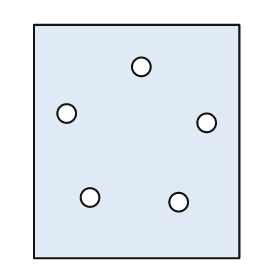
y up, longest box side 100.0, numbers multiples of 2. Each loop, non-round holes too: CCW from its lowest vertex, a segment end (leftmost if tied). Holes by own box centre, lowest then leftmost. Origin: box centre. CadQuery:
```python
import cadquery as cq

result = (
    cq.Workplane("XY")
    .moveTo(-44.0, -50.0)
    .lineTo(44.0, -50.0)
    .lineTo(44.0, 50.0)
    .lineTo(-44.0, 50.0)
    .close()
    .moveTo(18.0, -26.0)
    .circle(4.0)
    .moveTo(-20.0, -24.0)
    .circle(4.0)
    .moveTo(30.0, 8.0)
    .circle(4.0)
    .moveTo(-30.0, 12.0)
    .circle(4.0)
    .moveTo(2.0, 32.0)
    .circle(4.0)
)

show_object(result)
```